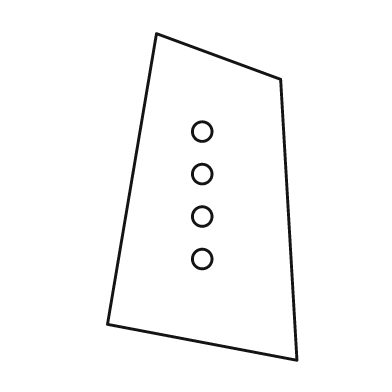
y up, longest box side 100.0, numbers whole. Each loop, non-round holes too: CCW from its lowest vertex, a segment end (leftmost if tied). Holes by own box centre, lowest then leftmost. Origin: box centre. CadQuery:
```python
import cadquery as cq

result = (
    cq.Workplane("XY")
    .moveTo(29.0, -50.0)
    .lineTo(24.0, 36.0)
    .lineTo(-14.0, 50.0)
    .lineTo(-29.0, -39.0)
    .close()
    .moveTo(0.0, -19.0)
    .circle(3.0)
    .moveTo(0.0, -6.0)
    .circle(3.0)
    .moveTo(0.0, 7.0)
    .circle(3.0)
    .moveTo(0.0, 20.0)
    .circle(3.0)
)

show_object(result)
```